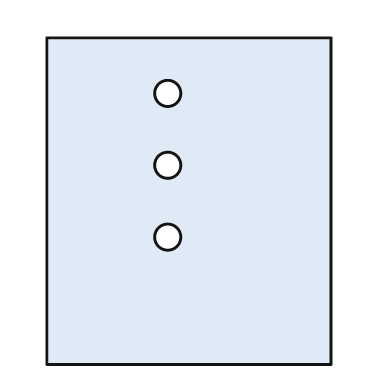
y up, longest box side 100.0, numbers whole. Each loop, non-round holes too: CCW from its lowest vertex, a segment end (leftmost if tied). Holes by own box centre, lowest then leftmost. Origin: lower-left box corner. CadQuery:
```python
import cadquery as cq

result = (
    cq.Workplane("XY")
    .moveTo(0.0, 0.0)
    .lineTo(87.0, 0.0)
    .lineTo(87.0, 100.0)
    .lineTo(0.0, 100.0)
    .close()
    .moveTo(37.0, 39.0)
    .circle(4.0)
    .moveTo(37.0, 61.0)
    .circle(4.0)
    .moveTo(37.0, 83.0)
    .circle(4.0)
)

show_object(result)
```